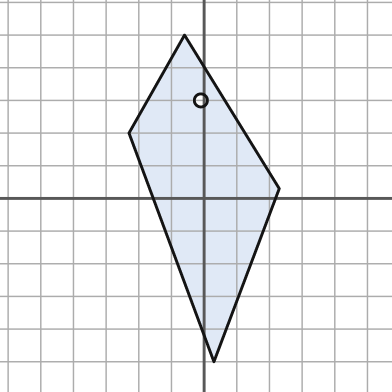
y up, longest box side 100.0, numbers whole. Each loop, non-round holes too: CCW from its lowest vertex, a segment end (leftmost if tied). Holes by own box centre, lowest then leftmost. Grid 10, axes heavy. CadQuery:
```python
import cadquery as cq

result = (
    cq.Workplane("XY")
    .moveTo(3.0, -50.0)
    .lineTo(23.0, 3.0)
    .lineTo(-6.0, 50.0)
    .lineTo(-23.0, 20.0)
    .close()
    .moveTo(-1.0, 30.0)
    .circle(2.0)
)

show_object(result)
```